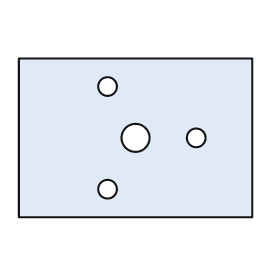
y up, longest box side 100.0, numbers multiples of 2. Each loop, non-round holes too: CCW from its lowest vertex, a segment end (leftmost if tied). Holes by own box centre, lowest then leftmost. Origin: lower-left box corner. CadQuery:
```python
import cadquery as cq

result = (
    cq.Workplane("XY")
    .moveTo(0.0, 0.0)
    .lineTo(100.0, 0.0)
    .lineTo(100.0, 68.0)
    .lineTo(0.0, 68.0)
    .close()
    .moveTo(38.0, 12.0)
    .circle(4.0)
    .moveTo(50.0, 34.0)
    .circle(6.0)
    .moveTo(76.0, 34.0)
    .circle(4.0)
    .moveTo(38.0, 56.0)
    .circle(4.0)
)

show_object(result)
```